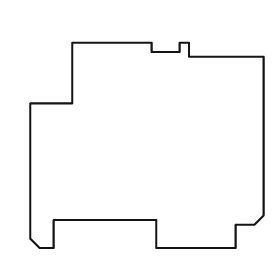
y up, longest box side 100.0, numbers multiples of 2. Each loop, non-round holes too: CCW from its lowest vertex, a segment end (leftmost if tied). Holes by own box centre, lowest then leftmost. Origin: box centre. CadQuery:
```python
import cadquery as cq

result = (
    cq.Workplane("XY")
    .moveTo(-46.0, -44.0)
    .lineTo(-40.0, -44.0)
    .lineTo(-40.0, -32.0)
    .lineTo(4.0, -32.0)
    .lineTo(4.0, -44.0)
    .lineTo(38.0, -44.0)
    .lineTo(38.0, -34.0)
    .lineTo(46.0, -34.0)
    .lineTo(50.0, -30.0)
    .lineTo(50.0, 38.0)
    .lineTo(18.0, 38.0)
    .lineTo(18.0, 44.0)
    .lineTo(14.0, 44.0)
    .lineTo(14.0, 40.0)
    .lineTo(2.0, 40.0)
    .lineTo(2.0, 44.0)
    .lineTo(-32.0, 44.0)
    .lineTo(-32.0, 18.0)
    .lineTo(-50.0, 18.0)
    .lineTo(-50.0, -40.0)
    .close()
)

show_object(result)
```